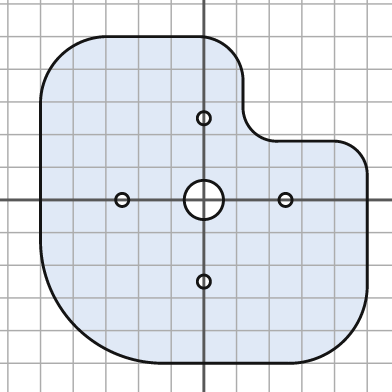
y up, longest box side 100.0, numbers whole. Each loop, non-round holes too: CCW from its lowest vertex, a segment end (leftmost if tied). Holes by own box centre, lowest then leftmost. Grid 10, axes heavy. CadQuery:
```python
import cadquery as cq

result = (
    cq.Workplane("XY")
    .moveTo(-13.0, -50.0)
    .lineTo(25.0, -50.0)
    .threePointArc((43.0, -43.0), (50.0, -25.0))
    .lineTo(50.0, 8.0)
    .threePointArc((47.0, 15.0), (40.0, 18.0))
    .lineTo(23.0, 18.0)
    .threePointArc((15.0, 21.0), (12.0, 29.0))
    .lineTo(12.0, 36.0)
    .threePointArc((8.0, 46.0), (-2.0, 50.0))
    .lineTo(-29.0, 50.0)
    .threePointArc((-44.0, 44.0), (-50.0, 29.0))
    .lineTo(-50.0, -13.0)
    .threePointArc((-39.0, -39.0), (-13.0, -50.0))
    .close()
    .moveTo(0.0, -25.0)
    .circle(2.0)
    .moveTo(-25.0, 0.0)
    .circle(2.0)
    .moveTo(0.0, 0.0)
    .circle(6.0)
    .moveTo(25.0, 0.0)
    .circle(2.0)
    .moveTo(0.0, 25.0)
    .circle(2.0)
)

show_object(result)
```